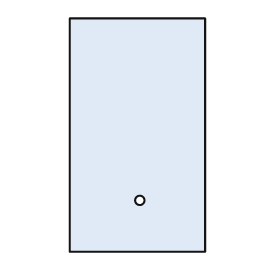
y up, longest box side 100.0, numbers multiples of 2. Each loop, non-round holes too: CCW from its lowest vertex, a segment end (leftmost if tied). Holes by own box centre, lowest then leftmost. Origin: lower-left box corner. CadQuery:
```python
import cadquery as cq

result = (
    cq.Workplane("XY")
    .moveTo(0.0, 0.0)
    .lineTo(58.0, 0.0)
    .lineTo(58.0, 100.0)
    .lineTo(0.0, 100.0)
    .close()
    .moveTo(30.0, 22.0)
    .circle(2.0)
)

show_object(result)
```